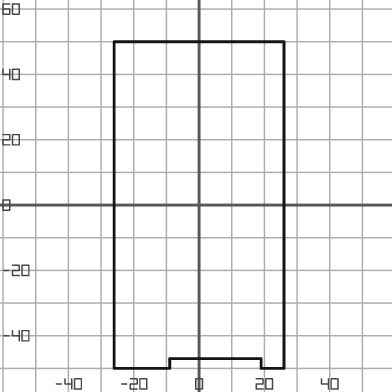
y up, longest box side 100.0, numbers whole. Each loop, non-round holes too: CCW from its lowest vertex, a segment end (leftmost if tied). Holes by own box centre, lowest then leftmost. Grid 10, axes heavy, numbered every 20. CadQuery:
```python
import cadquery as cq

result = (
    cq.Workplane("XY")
    .moveTo(-26.0, -50.0)
    .lineTo(-9.0, -50.0)
    .lineTo(-9.0, -47.0)
    .lineTo(19.0, -47.0)
    .lineTo(19.0, -50.0)
    .lineTo(26.0, -50.0)
    .lineTo(26.0, 50.0)
    .lineTo(-26.0, 50.0)
    .close()
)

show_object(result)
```